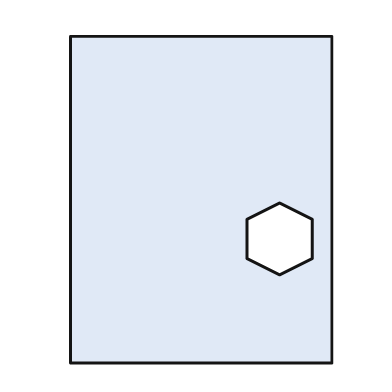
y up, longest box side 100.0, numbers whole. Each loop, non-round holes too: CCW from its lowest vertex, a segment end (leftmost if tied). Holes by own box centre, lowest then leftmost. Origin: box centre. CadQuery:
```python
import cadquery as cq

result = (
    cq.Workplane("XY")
    .moveTo(-40.0, -50.0)
    .lineTo(40.0, -50.0)
    .lineTo(40.0, 50.0)
    .lineTo(-40.0, 50.0)
    .close()
    .moveTo(24.0, -23.0)
    .lineTo(34.0, -18.0)
    .lineTo(34.0, -6.0)
    .lineTo(24.0, -1.0)
    .lineTo(14.0, -6.0)
    .lineTo(14.0, -18.0)
    .close()
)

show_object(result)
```